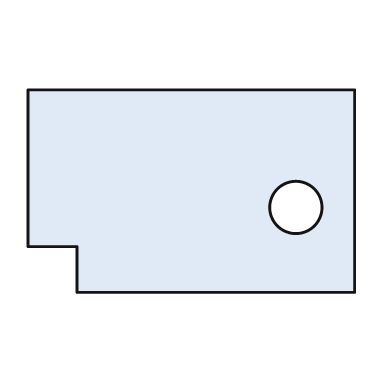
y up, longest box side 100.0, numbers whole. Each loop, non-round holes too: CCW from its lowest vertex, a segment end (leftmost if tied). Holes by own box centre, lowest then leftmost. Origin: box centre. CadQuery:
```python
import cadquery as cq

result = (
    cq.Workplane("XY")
    .moveTo(-35.0, -31.0)
    .lineTo(50.0, -31.0)
    .lineTo(50.0, 31.0)
    .lineTo(-50.0, 31.0)
    .lineTo(-50.0, -17.0)
    .lineTo(-35.0, -17.0)
    .close()
    .moveTo(32.0, -5.0)
    .circle(8.0)
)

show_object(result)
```